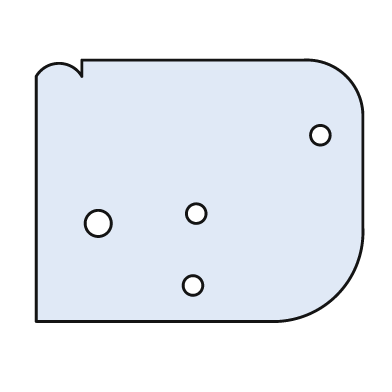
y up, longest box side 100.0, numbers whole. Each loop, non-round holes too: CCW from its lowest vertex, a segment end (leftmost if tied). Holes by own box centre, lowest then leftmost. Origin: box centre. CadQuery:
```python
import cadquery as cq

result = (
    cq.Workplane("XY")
    .moveTo(-50.0, -40.0)
    .lineTo(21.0, -40.0)
    .threePointArc((42.0, -32.0), (50.0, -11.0))
    .lineTo(50.0, 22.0)
    .threePointArc((45.0, 35.0), (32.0, 40.0))
    .lineTo(-36.0, 40.0)
    .lineTo(-36.0, 35.0)
    .threePointArc((-43.0, 39.0), (-50.0, 35.0))
    .close()
    .moveTo(-2.0, -29.0)
    .circle(3.0)
    .moveTo(-31.0, -10.0)
    .circle(4.0)
    .moveTo(-1.0, -7.0)
    .circle(3.0)
    .moveTo(37.0, 17.0)
    .circle(3.0)
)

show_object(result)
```